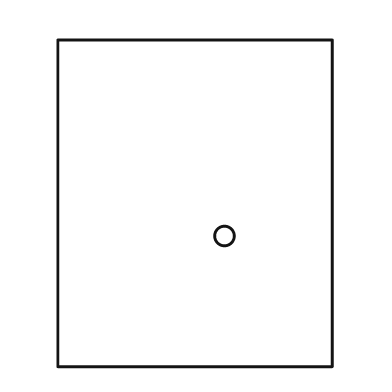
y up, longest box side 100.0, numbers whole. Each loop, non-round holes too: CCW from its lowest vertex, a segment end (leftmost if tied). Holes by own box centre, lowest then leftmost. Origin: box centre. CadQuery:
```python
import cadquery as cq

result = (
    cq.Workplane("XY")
    .moveTo(-42.0, -50.0)
    .lineTo(42.0, -50.0)
    .lineTo(42.0, 50.0)
    .lineTo(-42.0, 50.0)
    .close()
    .moveTo(9.0, -10.0)
    .circle(3.0)
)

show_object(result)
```